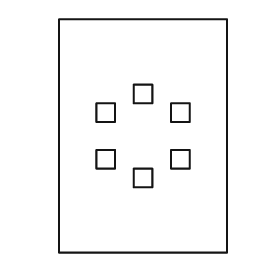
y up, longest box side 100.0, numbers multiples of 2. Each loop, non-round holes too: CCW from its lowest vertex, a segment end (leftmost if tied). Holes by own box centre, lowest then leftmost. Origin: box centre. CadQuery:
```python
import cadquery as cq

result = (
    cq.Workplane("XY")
    .moveTo(-36.0, -50.0)
    .lineTo(36.0, -50.0)
    .lineTo(36.0, 50.0)
    .lineTo(-36.0, 50.0)
    .close()
    .moveTo(-4.0, -22.0)
    .lineTo(4.0, -22.0)
    .lineTo(4.0, -14.0)
    .lineTo(-4.0, -14.0)
    .close()
    .moveTo(-20.0, -14.0)
    .lineTo(-12.0, -14.0)
    .lineTo(-12.0, -6.0)
    .lineTo(-20.0, -6.0)
    .close()
    .moveTo(12.0, -14.0)
    .lineTo(20.0, -14.0)
    .lineTo(20.0, -6.0)
    .lineTo(12.0, -6.0)
    .close()
    .moveTo(-20.0, 6.0)
    .lineTo(-12.0, 6.0)
    .lineTo(-12.0, 14.0)
    .lineTo(-20.0, 14.0)
    .close()
    .moveTo(12.0, 6.0)
    .lineTo(20.0, 6.0)
    .lineTo(20.0, 14.0)
    .lineTo(12.0, 14.0)
    .close()
    .moveTo(-4.0, 14.0)
    .lineTo(4.0, 14.0)
    .lineTo(4.0, 22.0)
    .lineTo(-4.0, 22.0)
    .close()
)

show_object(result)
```